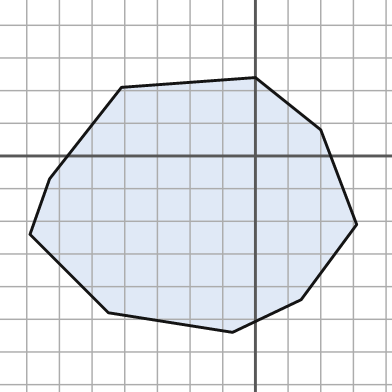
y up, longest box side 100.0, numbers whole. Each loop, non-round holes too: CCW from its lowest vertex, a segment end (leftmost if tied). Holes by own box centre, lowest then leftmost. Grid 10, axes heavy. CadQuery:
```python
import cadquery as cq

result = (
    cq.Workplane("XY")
    .moveTo(-7.0, -54.0)
    .lineTo(14.0, -44.0)
    .lineTo(31.0, -21.0)
    .lineTo(20.0, 8.0)
    .lineTo(0.0, 24.0)
    .lineTo(-41.0, 21.0)
    .lineTo(-63.0, -7.0)
    .lineTo(-69.0, -24.0)
    .lineTo(-45.0, -48.0)
    .close()
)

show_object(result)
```